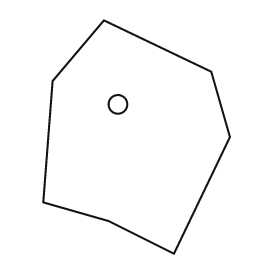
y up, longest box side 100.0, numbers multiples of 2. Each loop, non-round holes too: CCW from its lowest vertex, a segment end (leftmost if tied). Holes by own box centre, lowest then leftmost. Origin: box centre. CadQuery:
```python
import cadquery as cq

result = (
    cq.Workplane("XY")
    .moveTo(16.0, -50.0)
    .lineTo(40.0, 0.0)
    .lineTo(32.0, 28.0)
    .lineTo(-14.0, 50.0)
    .lineTo(-36.0, 24.0)
    .lineTo(-40.0, -28.0)
    .lineTo(-12.0, -36.0)
    .close()
    .moveTo(-8.0, 14.0)
    .circle(4.0)
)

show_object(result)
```